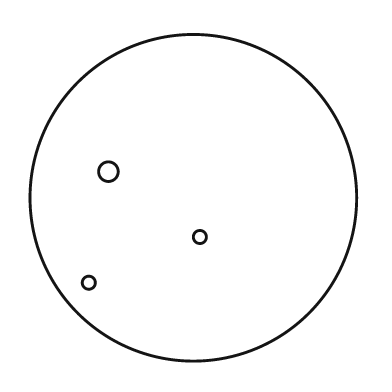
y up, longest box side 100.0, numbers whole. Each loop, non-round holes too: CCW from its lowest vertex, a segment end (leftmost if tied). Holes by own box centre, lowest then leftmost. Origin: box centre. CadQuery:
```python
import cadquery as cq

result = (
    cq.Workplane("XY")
    .moveTo(0.0, 0.0)
    .circle(50.0)
    .moveTo(-32.0, -26.0)
    .circle(2.0)
    .moveTo(2.0, -12.0)
    .circle(2.0)
    .moveTo(-26.0, 8.0)
    .circle(3.0)
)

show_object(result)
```